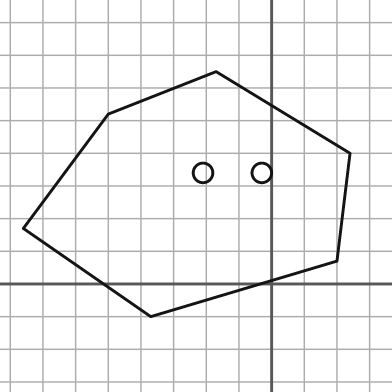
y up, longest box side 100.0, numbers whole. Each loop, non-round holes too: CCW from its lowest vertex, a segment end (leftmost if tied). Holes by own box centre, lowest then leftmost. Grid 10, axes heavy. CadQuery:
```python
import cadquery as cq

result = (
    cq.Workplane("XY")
    .moveTo(-37.0, -10.0)
    .lineTo(20.0, 7.0)
    .lineTo(24.0, 40.0)
    .lineTo(-17.0, 65.0)
    .lineTo(-50.0, 52.0)
    .lineTo(-76.0, 17.0)
    .close()
    .moveTo(-21.0, 34.0)
    .circle(3.0)
    .moveTo(-3.0, 34.0)
    .circle(3.0)
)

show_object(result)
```